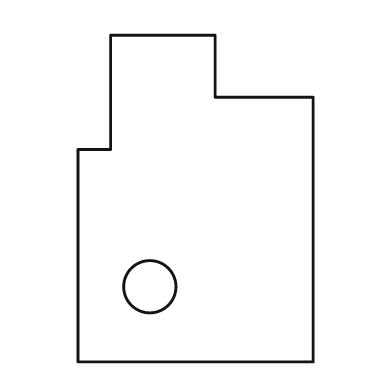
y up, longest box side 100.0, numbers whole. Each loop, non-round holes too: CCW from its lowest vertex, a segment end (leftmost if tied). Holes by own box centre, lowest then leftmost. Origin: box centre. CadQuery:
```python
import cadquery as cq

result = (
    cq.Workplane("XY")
    .moveTo(-36.0, -50.0)
    .lineTo(36.0, -50.0)
    .lineTo(36.0, 31.0)
    .lineTo(6.0, 31.0)
    .lineTo(6.0, 50.0)
    .lineTo(-26.0, 50.0)
    .lineTo(-26.0, 15.0)
    .lineTo(-36.0, 15.0)
    .close()
    .moveTo(-14.0, -27.0)
    .circle(8.0)
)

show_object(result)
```